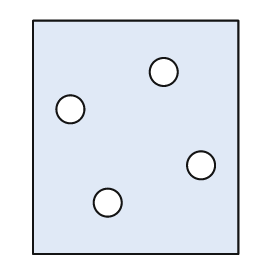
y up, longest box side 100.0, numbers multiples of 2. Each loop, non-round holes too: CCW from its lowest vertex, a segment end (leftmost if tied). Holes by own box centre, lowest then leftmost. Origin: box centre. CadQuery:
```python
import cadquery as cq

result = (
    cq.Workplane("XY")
    .moveTo(-44.0, -50.0)
    .lineTo(44.0, -50.0)
    .lineTo(44.0, 50.0)
    .lineTo(-44.0, 50.0)
    .close()
    .moveTo(-12.0, -28.0)
    .circle(6.0)
    .moveTo(28.0, -12.0)
    .circle(6.0)
    .moveTo(-28.0, 12.0)
    .circle(6.0)
    .moveTo(12.0, 28.0)
    .circle(6.0)
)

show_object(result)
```